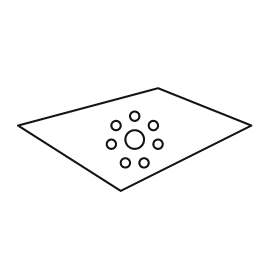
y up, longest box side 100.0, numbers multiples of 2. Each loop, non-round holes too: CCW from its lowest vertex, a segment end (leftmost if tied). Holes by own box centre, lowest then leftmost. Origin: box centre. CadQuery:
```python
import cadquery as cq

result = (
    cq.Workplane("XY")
    .moveTo(-6.0, -22.0)
    .lineTo(50.0, 6.0)
    .lineTo(10.0, 22.0)
    .lineTo(-50.0, 6.0)
    .close()
    .moveTo(-4.0, -10.0)
    .circle(2.0)
    .moveTo(4.0, -10.0)
    .circle(2.0)
    .moveTo(-10.0, -2.0)
    .circle(2.0)
    .moveTo(10.0, -2.0)
    .circle(2.0)
    .moveTo(0.0, 0.0)
    .circle(4.0)
    .moveTo(-8.0, 6.0)
    .circle(2.0)
    .moveTo(8.0, 6.0)
    .circle(2.0)
    .moveTo(0.0, 10.0)
    .circle(2.0)
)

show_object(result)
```